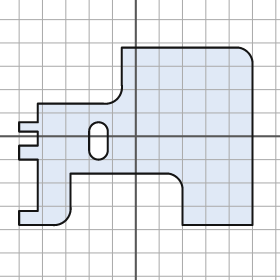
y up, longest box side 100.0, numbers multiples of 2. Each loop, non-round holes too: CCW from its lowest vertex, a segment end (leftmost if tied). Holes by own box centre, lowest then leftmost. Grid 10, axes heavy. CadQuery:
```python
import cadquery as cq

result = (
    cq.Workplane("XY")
    .moveTo(-50.0, -38.0)
    .lineTo(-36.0, -38.0)
    .threePointArc((-30.0, -36.0), (-28.0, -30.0))
    .lineTo(-28.0, -16.0)
    .lineTo(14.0, -16.0)
    .threePointArc((18.0, -18.0), (20.0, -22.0))
    .lineTo(20.0, -38.0)
    .lineTo(50.0, -38.0)
    .lineTo(50.0, 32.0)
    .threePointArc((48.0, 36.0), (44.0, 38.0))
    .lineTo(-6.0, 38.0)
    .lineTo(-6.0, 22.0)
    .threePointArc((-8.0, 16.0), (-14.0, 14.0))
    .lineTo(-42.0, 14.0)
    .lineTo(-42.0, 6.0)
    .lineTo(-50.0, 6.0)
    .lineTo(-50.0, 2.0)
    .lineTo(-42.0, 2.0)
    .lineTo(-42.0, -4.0)
    .lineTo(-50.0, -4.0)
    .lineTo(-50.0, -10.0)
    .lineTo(-42.0, -10.0)
    .lineTo(-42.0, -32.0)
    .lineTo(-50.0, -32.0)
    .close()
    .moveTo(-20.0, -6.0)
    .threePointArc((-16.0, -10.0), (-12.0, -6.0))
    .lineTo(-12.0, 2.0)
    .threePointArc((-16.0, 6.0), (-20.0, 2.0))
    .close()
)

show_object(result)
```